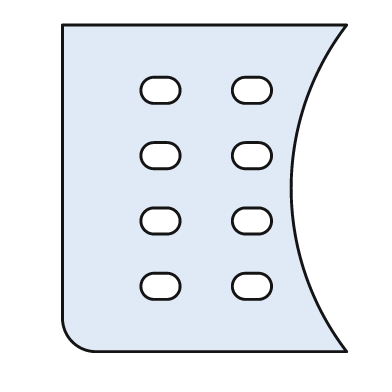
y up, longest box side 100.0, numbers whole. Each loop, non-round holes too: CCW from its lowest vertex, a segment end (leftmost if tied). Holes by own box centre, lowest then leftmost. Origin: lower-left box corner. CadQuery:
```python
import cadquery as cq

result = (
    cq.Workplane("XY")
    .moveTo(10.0, 0.0)
    .lineTo(87.0, 0.0)
    .threePointArc((70.0, 50.0), (87.0, 100.0))
    .lineTo(0.0, 100.0)
    .lineTo(0.0, 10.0)
    .threePointArc((3.0, 3.0), (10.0, 0.0))
    .close()
    .moveTo(28.0, 16.0)
    .lineTo(32.0, 16.0)
    .threePointArc((36.0, 20.0), (32.0, 24.0))
    .lineTo(28.0, 24.0)
    .threePointArc((24.0, 20.0), (28.0, 16.0))
    .close()
    .moveTo(56.0, 16.0)
    .lineTo(60.0, 16.0)
    .threePointArc((64.0, 20.0), (60.0, 24.0))
    .lineTo(56.0, 24.0)
    .threePointArc((52.0, 20.0), (56.0, 16.0))
    .close()
    .moveTo(28.0, 36.0)
    .lineTo(32.0, 36.0)
    .threePointArc((36.0, 40.0), (32.0, 44.0))
    .lineTo(28.0, 44.0)
    .threePointArc((24.0, 40.0), (28.0, 36.0))
    .close()
    .moveTo(56.0, 36.0)
    .lineTo(60.0, 36.0)
    .threePointArc((64.0, 40.0), (60.0, 44.0))
    .lineTo(56.0, 44.0)
    .threePointArc((52.0, 40.0), (56.0, 36.0))
    .close()
    .moveTo(28.0, 56.0)
    .lineTo(32.0, 56.0)
    .threePointArc((36.0, 60.0), (32.0, 64.0))
    .lineTo(28.0, 64.0)
    .threePointArc((24.0, 60.0), (28.0, 56.0))
    .close()
    .moveTo(56.0, 56.0)
    .lineTo(60.0, 56.0)
    .threePointArc((64.0, 60.0), (60.0, 64.0))
    .lineTo(56.0, 64.0)
    .threePointArc((52.0, 60.0), (56.0, 56.0))
    .close()
    .moveTo(28.0, 76.0)
    .lineTo(32.0, 76.0)
    .threePointArc((36.0, 80.0), (32.0, 84.0))
    .lineTo(28.0, 84.0)
    .threePointArc((24.0, 80.0), (28.0, 76.0))
    .close()
    .moveTo(56.0, 76.0)
    .lineTo(60.0, 76.0)
    .threePointArc((64.0, 80.0), (60.0, 84.0))
    .lineTo(56.0, 84.0)
    .threePointArc((52.0, 80.0), (56.0, 76.0))
    .close()
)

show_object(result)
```